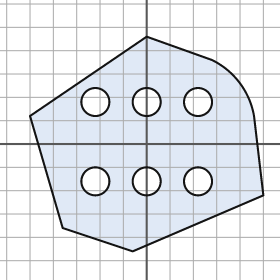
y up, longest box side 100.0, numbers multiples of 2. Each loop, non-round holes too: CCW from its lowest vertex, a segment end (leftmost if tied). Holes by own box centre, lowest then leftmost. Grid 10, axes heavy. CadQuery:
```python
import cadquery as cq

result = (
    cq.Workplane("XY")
    .moveTo(-6.0, -46.0)
    .lineTo(50.0, -22.0)
    .lineTo(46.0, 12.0)
    .threePointArc((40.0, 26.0), (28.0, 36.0))
    .lineTo(0.0, 46.0)
    .lineTo(-50.0, 12.0)
    .lineTo(-36.0, -36.0)
    .close()
    .moveTo(-22.0, -16.0)
    .circle(6.0)
    .moveTo(0.0, -16.0)
    .circle(6.0)
    .moveTo(22.0, -16.0)
    .circle(6.0)
    .moveTo(-22.0, 18.0)
    .circle(6.0)
    .moveTo(0.0, 18.0)
    .circle(6.0)
    .moveTo(22.0, 18.0)
    .circle(6.0)
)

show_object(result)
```